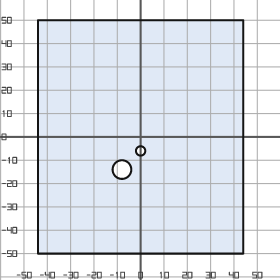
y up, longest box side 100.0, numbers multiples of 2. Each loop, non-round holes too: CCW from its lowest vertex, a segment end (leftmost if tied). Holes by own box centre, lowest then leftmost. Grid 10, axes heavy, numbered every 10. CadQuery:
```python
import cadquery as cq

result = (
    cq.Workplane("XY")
    .moveTo(-44.0, -50.0)
    .lineTo(44.0, -50.0)
    .lineTo(44.0, 50.0)
    .lineTo(-44.0, 50.0)
    .close()
    .moveTo(-8.0, -14.0)
    .circle(4.0)
    .moveTo(0.0, -6.0)
    .circle(2.0)
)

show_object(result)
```